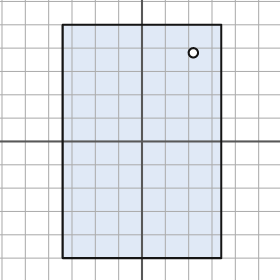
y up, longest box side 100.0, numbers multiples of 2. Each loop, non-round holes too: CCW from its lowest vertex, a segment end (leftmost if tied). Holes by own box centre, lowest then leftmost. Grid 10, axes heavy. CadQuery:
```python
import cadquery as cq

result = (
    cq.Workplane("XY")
    .moveTo(-34.0, -50.0)
    .lineTo(34.0, -50.0)
    .lineTo(34.0, 50.0)
    .lineTo(-34.0, 50.0)
    .close()
    .moveTo(22.0, 38.0)
    .circle(2.0)
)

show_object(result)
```